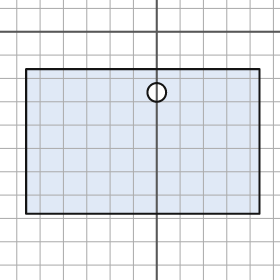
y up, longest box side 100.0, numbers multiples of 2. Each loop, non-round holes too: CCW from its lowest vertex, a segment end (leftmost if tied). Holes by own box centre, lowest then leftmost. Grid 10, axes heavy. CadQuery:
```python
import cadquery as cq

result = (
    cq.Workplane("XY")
    .moveTo(-56.0, -78.0)
    .lineTo(44.0, -78.0)
    .lineTo(44.0, -16.0)
    .lineTo(-56.0, -16.0)
    .close()
    .moveTo(0.0, -26.0)
    .circle(4.0)
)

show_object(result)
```